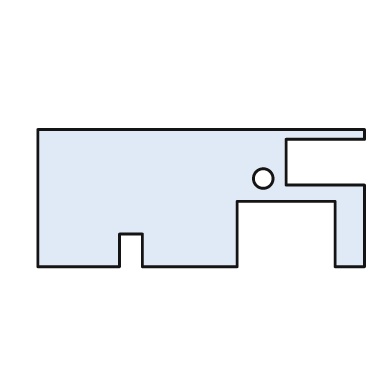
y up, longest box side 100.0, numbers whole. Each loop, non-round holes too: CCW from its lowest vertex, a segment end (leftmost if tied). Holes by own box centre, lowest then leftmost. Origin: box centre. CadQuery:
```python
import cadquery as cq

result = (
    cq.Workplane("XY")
    .moveTo(-50.0, -21.0)
    .lineTo(-25.0, -21.0)
    .lineTo(-25.0, -11.0)
    .lineTo(-18.0, -11.0)
    .lineTo(-18.0, -21.0)
    .lineTo(11.0, -21.0)
    .lineTo(11.0, -1.0)
    .lineTo(41.0, -1.0)
    .lineTo(41.0, -21.0)
    .lineTo(50.0, -21.0)
    .lineTo(50.0, 4.0)
    .lineTo(26.0, 4.0)
    .lineTo(26.0, 18.0)
    .lineTo(50.0, 18.0)
    .lineTo(50.0, 21.0)
    .lineTo(-50.0, 21.0)
    .close()
    .moveTo(19.0, 6.0)
    .circle(3.0)
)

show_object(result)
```